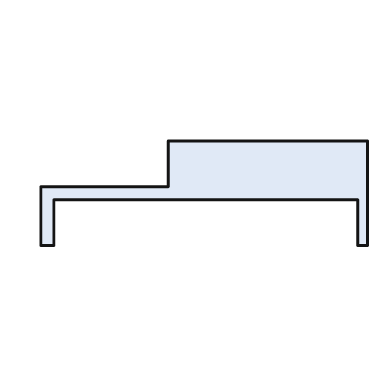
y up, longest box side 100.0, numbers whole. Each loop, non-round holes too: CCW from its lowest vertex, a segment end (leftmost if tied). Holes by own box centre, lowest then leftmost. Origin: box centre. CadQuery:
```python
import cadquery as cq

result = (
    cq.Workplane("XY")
    .moveTo(-50.0, -16.0)
    .lineTo(-46.0, -16.0)
    .lineTo(-46.0, -2.0)
    .lineTo(47.0, -2.0)
    .lineTo(47.0, -16.0)
    .lineTo(50.0, -16.0)
    .lineTo(50.0, 16.0)
    .lineTo(-11.0, 16.0)
    .lineTo(-11.0, 2.0)
    .lineTo(-50.0, 2.0)
    .close()
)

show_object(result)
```